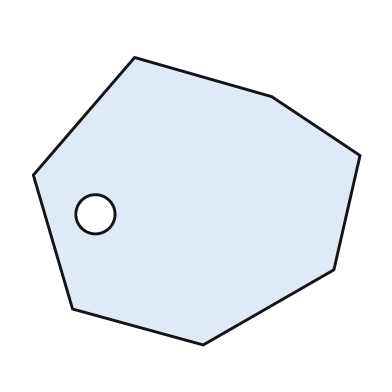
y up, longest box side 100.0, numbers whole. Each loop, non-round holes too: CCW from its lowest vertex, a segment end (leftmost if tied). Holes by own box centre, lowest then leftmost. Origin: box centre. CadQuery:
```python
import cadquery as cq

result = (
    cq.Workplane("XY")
    .moveTo(2.0, -44.0)
    .lineTo(42.0, -21.0)
    .lineTo(50.0, 14.0)
    .lineTo(23.0, 32.0)
    .lineTo(-19.0, 44.0)
    .lineTo(-50.0, 8.0)
    .lineTo(-38.0, -33.0)
    .close()
    .moveTo(-31.0, -4.0)
    .circle(6.0)
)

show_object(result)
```